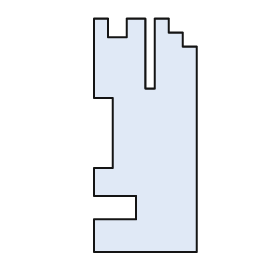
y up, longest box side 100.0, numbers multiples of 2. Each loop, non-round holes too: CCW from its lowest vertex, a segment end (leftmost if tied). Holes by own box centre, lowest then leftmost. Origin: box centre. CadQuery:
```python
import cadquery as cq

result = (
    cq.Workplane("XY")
    .moveTo(-22.0, -50.0)
    .lineTo(22.0, -50.0)
    .lineTo(22.0, 38.0)
    .lineTo(16.0, 38.0)
    .lineTo(16.0, 44.0)
    .lineTo(10.0, 44.0)
    .lineTo(10.0, 50.0)
    .lineTo(4.0, 50.0)
    .lineTo(4.0, 20.0)
    .lineTo(0.0, 20.0)
    .lineTo(0.0, 50.0)
    .lineTo(-8.0, 50.0)
    .lineTo(-8.0, 42.0)
    .lineTo(-16.0, 42.0)
    .lineTo(-16.0, 50.0)
    .lineTo(-22.0, 50.0)
    .lineTo(-22.0, 16.0)
    .lineTo(-14.0, 16.0)
    .lineTo(-14.0, -14.0)
    .lineTo(-22.0, -14.0)
    .lineTo(-22.0, -26.0)
    .lineTo(-4.0, -26.0)
    .lineTo(-4.0, -36.0)
    .lineTo(-22.0, -36.0)
    .close()
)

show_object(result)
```